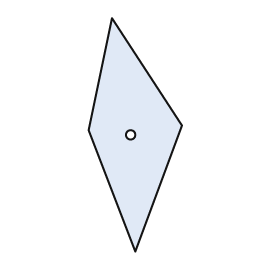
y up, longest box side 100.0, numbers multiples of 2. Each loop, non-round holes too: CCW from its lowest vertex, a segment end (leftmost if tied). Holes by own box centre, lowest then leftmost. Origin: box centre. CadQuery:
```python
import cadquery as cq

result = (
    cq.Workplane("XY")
    .moveTo(0.0, -50.0)
    .lineTo(20.0, 4.0)
    .lineTo(-10.0, 50.0)
    .lineTo(-20.0, 2.0)
    .close()
    .moveTo(-2.0, 0.0)
    .circle(2.0)
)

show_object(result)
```